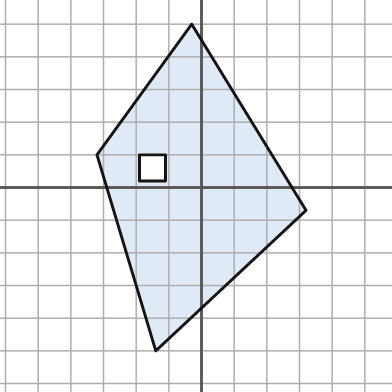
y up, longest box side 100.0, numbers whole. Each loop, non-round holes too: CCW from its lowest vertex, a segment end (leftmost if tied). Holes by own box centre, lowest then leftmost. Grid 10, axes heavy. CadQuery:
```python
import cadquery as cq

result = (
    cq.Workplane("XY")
    .moveTo(-14.0, -50.0)
    .lineTo(32.0, -7.0)
    .lineTo(-3.0, 50.0)
    .lineTo(-32.0, 10.0)
    .close()
    .moveTo(-19.0, 2.0)
    .lineTo(-11.0, 2.0)
    .lineTo(-11.0, 10.0)
    .lineTo(-19.0, 10.0)
    .close()
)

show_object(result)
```